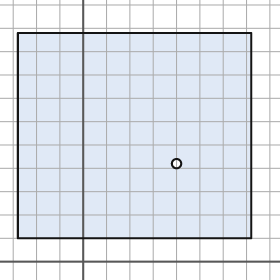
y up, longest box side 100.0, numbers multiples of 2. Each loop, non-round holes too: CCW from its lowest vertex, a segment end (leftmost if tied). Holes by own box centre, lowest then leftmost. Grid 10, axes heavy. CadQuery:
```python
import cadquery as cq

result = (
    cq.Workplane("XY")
    .moveTo(-28.0, 10.0)
    .lineTo(72.0, 10.0)
    .lineTo(72.0, 98.0)
    .lineTo(-28.0, 98.0)
    .close()
    .moveTo(40.0, 42.0)
    .circle(2.0)
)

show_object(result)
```